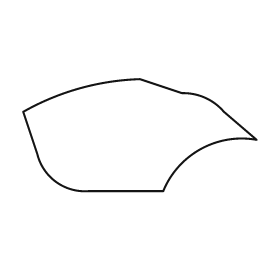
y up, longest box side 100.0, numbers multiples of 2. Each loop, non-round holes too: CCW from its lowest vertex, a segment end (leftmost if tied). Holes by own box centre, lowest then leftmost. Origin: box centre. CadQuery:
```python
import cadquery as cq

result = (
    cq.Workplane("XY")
    .moveTo(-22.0, -24.0)
    .lineTo(10.0, -24.0)
    .threePointArc((26.0, -6.0), (50.0, -2.0))
    .lineTo(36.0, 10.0)
    .threePointArc((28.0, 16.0), (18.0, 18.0))
    .lineTo(0.0, 24.0)
    .threePointArc((-26.0, 20.0), (-50.0, 10.0))
    .lineTo(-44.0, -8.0)
    .threePointArc((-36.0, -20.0), (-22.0, -24.0))
    .close()
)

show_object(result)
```